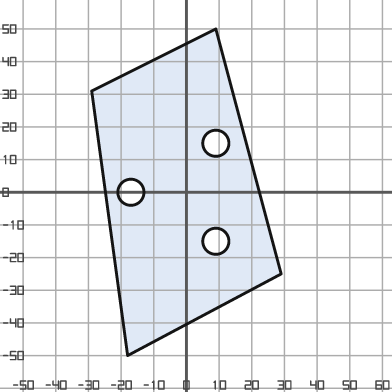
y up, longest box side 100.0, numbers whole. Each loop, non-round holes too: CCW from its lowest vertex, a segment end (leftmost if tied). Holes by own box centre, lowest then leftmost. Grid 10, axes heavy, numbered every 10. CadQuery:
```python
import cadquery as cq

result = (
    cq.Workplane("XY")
    .moveTo(-18.0, -50.0)
    .lineTo(29.0, -25.0)
    .lineTo(9.0, 50.0)
    .lineTo(-29.0, 31.0)
    .close()
    .moveTo(9.0, -15.0)
    .circle(4.0)
    .moveTo(-17.0, 0.0)
    .circle(4.0)
    .moveTo(9.0, 15.0)
    .circle(4.0)
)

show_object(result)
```